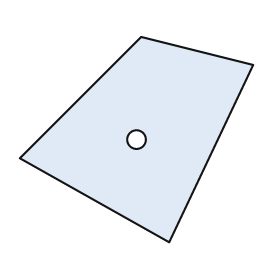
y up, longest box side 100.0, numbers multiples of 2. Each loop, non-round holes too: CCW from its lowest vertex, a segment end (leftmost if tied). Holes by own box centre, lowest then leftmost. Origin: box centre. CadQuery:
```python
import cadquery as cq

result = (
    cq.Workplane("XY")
    .moveTo(14.0, -44.0)
    .lineTo(50.0, 32.0)
    .lineTo(2.0, 44.0)
    .lineTo(-50.0, -8.0)
    .close()
    .moveTo(0.0, 0.0)
    .circle(4.0)
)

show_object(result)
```